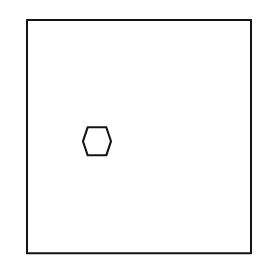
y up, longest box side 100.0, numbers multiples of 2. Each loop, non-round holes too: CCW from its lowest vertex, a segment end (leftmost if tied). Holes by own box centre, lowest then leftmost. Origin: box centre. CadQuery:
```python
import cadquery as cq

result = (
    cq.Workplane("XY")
    .moveTo(-48.0, -50.0)
    .lineTo(48.0, -50.0)
    .lineTo(48.0, 50.0)
    .lineTo(-48.0, 50.0)
    .close()
    .moveTo(-22.0, -8.0)
    .lineTo(-14.0, -8.0)
    .lineTo(-12.0, -2.0)
    .lineTo(-14.0, 4.0)
    .lineTo(-22.0, 4.0)
    .lineTo(-24.0, -2.0)
    .close()
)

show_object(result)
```